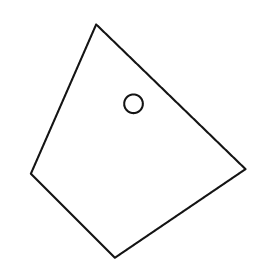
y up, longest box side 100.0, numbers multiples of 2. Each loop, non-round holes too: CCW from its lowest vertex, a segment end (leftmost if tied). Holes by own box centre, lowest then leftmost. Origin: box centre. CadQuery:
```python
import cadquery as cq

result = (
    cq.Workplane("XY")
    .moveTo(-10.0, -50.0)
    .lineTo(46.0, -12.0)
    .lineTo(-18.0, 50.0)
    .lineTo(-46.0, -14.0)
    .close()
    .moveTo(-2.0, 16.0)
    .circle(4.0)
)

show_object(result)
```